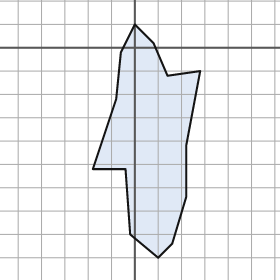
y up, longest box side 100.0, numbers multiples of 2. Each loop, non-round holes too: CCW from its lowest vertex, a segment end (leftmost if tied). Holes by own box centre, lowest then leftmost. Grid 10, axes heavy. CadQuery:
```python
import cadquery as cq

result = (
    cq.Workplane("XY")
    .moveTo(10.0, -90.0)
    .lineTo(16.0, -84.0)
    .lineTo(22.0, -64.0)
    .lineTo(22.0, -42.0)
    .lineTo(28.0, -10.0)
    .lineTo(14.0, -12.0)
    .lineTo(8.0, 2.0)
    .lineTo(0.0, 10.0)
    .lineTo(-6.0, -2.0)
    .lineTo(-8.0, -22.0)
    .lineTo(-18.0, -52.0)
    .lineTo(-4.0, -52.0)
    .lineTo(-2.0, -80.0)
    .close()
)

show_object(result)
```